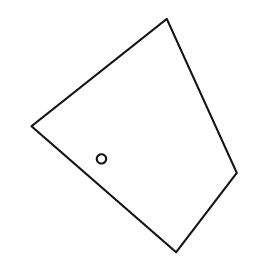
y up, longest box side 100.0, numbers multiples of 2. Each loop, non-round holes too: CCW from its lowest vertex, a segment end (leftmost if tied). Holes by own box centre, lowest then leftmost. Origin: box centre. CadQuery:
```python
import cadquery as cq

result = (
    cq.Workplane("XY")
    .moveTo(18.0, -50.0)
    .lineTo(44.0, -16.0)
    .lineTo(14.0, 50.0)
    .lineTo(-44.0, 4.0)
    .close()
    .moveTo(-14.0, -10.0)
    .circle(2.0)
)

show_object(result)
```